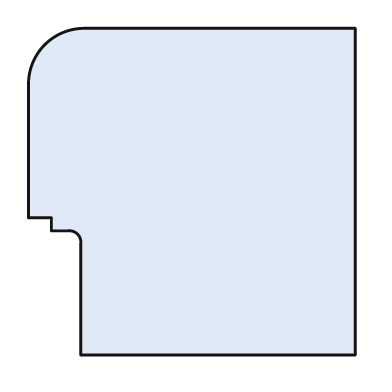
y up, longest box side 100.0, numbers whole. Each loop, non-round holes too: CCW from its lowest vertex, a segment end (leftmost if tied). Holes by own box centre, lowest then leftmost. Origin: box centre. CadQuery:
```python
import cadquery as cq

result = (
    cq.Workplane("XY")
    .moveTo(-34.0, -50.0)
    .lineTo(50.0, -50.0)
    .lineTo(50.0, 50.0)
    .lineTo(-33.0, 50.0)
    .threePointArc((-45.0, 45.0), (-50.0, 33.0))
    .lineTo(-50.0, -8.0)
    .lineTo(-43.0, -8.0)
    .lineTo(-43.0, -12.0)
    .lineTo(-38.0, -12.0)
    .threePointArc((-35.0, -13.0), (-34.0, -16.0))
    .close()
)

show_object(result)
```